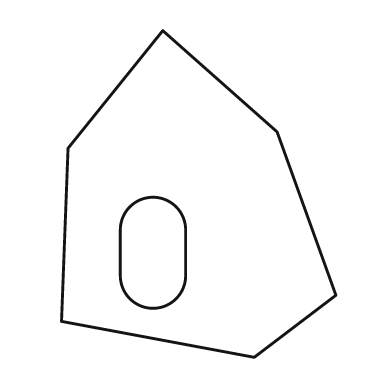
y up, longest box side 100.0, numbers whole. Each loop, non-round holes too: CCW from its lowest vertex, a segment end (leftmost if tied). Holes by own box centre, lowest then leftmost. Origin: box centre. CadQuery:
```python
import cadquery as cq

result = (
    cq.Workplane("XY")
    .moveTo(17.0, -50.0)
    .lineTo(42.0, -31.0)
    .lineTo(24.0, 19.0)
    .lineTo(-11.0, 50.0)
    .lineTo(-40.0, 14.0)
    .lineTo(-42.0, -39.0)
    .close()
    .moveTo(-24.0, -25.0)
    .threePointArc((-14.0, -35.0), (-4.0, -25.0))
    .lineTo(-4.0, -11.0)
    .threePointArc((-14.0, -1.0), (-24.0, -11.0))
    .close()
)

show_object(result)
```